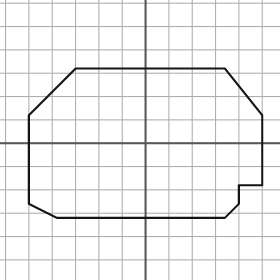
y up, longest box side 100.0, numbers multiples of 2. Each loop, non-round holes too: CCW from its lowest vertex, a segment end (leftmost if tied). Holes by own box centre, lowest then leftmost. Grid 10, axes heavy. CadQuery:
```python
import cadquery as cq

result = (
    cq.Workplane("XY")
    .moveTo(-38.0, -32.0)
    .lineTo(34.0, -32.0)
    .lineTo(40.0, -26.0)
    .lineTo(40.0, -18.0)
    .lineTo(50.0, -18.0)
    .lineTo(50.0, 12.0)
    .lineTo(34.0, 32.0)
    .lineTo(-30.0, 32.0)
    .lineTo(-50.0, 12.0)
    .lineTo(-50.0, -26.0)
    .close()
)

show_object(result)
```